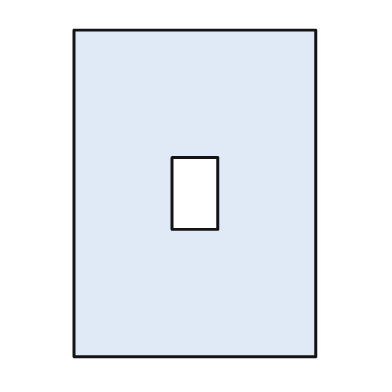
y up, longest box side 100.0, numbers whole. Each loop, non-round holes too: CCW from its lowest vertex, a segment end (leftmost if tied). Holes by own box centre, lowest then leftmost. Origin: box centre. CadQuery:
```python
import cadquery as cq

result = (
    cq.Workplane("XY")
    .moveTo(-37.0, -50.0)
    .lineTo(37.0, -50.0)
    .lineTo(37.0, 50.0)
    .lineTo(-37.0, 50.0)
    .close()
    .moveTo(-7.0, -11.0)
    .lineTo(7.0, -11.0)
    .lineTo(7.0, 11.0)
    .lineTo(-7.0, 11.0)
    .close()
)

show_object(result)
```